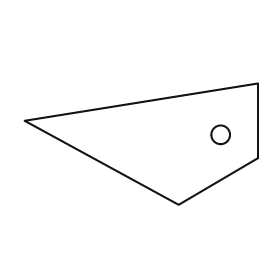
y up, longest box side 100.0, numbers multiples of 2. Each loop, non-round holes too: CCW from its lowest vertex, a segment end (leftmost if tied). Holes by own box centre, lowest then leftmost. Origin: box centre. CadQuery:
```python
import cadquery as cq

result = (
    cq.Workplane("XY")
    .moveTo(16.0, -26.0)
    .lineTo(50.0, -6.0)
    .lineTo(50.0, 26.0)
    .lineTo(-50.0, 10.0)
    .close()
    .moveTo(34.0, 4.0)
    .circle(4.0)
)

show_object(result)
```